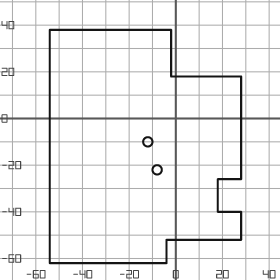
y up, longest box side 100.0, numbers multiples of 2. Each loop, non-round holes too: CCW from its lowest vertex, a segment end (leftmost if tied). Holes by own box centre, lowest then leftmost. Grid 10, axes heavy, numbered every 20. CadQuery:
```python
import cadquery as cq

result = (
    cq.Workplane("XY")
    .moveTo(-54.0, -62.0)
    .lineTo(-4.0, -62.0)
    .lineTo(-4.0, -52.0)
    .lineTo(28.0, -52.0)
    .lineTo(28.0, -40.0)
    .lineTo(18.0, -40.0)
    .lineTo(18.0, -26.0)
    .lineTo(28.0, -26.0)
    .lineTo(28.0, 18.0)
    .lineTo(-2.0, 18.0)
    .lineTo(-2.0, 38.0)
    .lineTo(-54.0, 38.0)
    .close()
    .moveTo(-8.0, -22.0)
    .circle(2.0)
    .moveTo(-12.0, -10.0)
    .circle(2.0)
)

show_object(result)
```